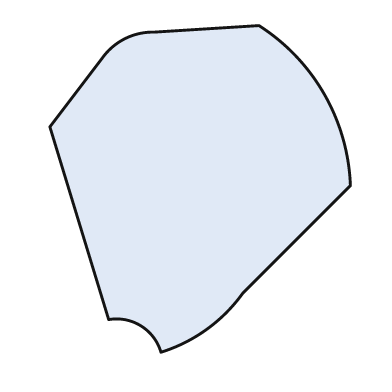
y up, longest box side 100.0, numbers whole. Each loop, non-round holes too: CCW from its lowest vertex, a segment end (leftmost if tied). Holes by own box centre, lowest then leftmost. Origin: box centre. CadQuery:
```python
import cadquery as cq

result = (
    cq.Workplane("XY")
    .moveTo(-12.0, -50.0)
    .threePointArc((2.0, -43.0), (13.0, -32.0))
    .lineTo(46.0, 1.0)
    .threePointArc((38.0, 29.0), (18.0, 50.0))
    .lineTo(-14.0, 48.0)
    .threePointArc((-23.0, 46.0), (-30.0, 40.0))
    .lineTo(-46.0, 19.0)
    .lineTo(-28.0, -40.0)
    .threePointArc((-18.0, -42.0), (-12.0, -50.0))
    .close()
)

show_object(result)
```